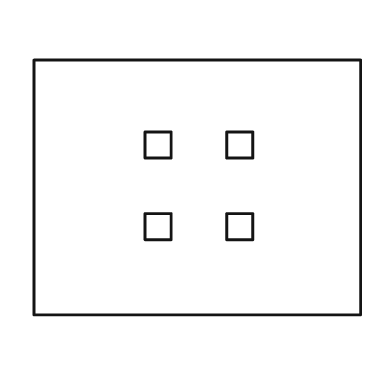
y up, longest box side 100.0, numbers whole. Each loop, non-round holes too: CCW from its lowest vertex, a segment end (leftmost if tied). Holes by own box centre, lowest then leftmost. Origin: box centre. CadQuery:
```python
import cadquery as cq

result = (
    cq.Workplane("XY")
    .moveTo(-50.0, -39.0)
    .lineTo(50.0, -39.0)
    .lineTo(50.0, 39.0)
    .lineTo(-50.0, 39.0)
    .close()
    .moveTo(-16.0, -16.0)
    .lineTo(-8.0, -16.0)
    .lineTo(-8.0, -8.0)
    .lineTo(-16.0, -8.0)
    .close()
    .moveTo(9.0, -16.0)
    .lineTo(17.0, -16.0)
    .lineTo(17.0, -8.0)
    .lineTo(9.0, -8.0)
    .close()
    .moveTo(-16.0, 9.0)
    .lineTo(-8.0, 9.0)
    .lineTo(-8.0, 17.0)
    .lineTo(-16.0, 17.0)
    .close()
    .moveTo(9.0, 9.0)
    .lineTo(17.0, 9.0)
    .lineTo(17.0, 17.0)
    .lineTo(9.0, 17.0)
    .close()
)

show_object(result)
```